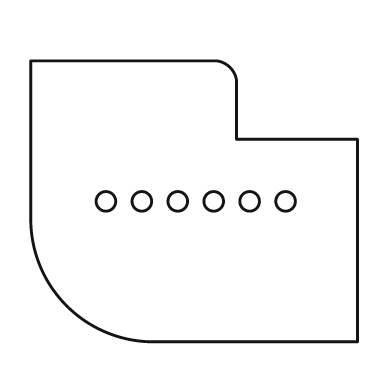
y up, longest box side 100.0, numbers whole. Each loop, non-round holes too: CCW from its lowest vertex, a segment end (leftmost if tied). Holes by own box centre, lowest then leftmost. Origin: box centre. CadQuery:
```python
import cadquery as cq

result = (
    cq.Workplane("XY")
    .moveTo(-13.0, -43.0)
    .lineTo(50.0, -43.0)
    .lineTo(50.0, 19.0)
    .lineTo(13.0, 19.0)
    .lineTo(13.0, 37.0)
    .threePointArc((11.0, 41.0), (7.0, 43.0))
    .lineTo(-50.0, 43.0)
    .lineTo(-50.0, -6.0)
    .threePointArc((-39.0, -32.0), (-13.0, -43.0))
    .close()
    .moveTo(-27.0, 0.0)
    .circle(3.0)
    .moveTo(-16.0, 0.0)
    .circle(3.0)
    .moveTo(-5.0, 0.0)
    .circle(3.0)
    .moveTo(6.0, 0.0)
    .circle(3.0)
    .moveTo(17.0, 0.0)
    .circle(3.0)
    .moveTo(28.0, 0.0)
    .circle(3.0)
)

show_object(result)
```